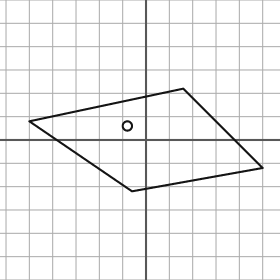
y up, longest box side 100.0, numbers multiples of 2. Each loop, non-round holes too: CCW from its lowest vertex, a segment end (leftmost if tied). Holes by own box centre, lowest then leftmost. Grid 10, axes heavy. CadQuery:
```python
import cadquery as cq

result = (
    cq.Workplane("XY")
    .moveTo(-6.0, -22.0)
    .lineTo(50.0, -12.0)
    .lineTo(16.0, 22.0)
    .lineTo(-50.0, 8.0)
    .close()
    .moveTo(-8.0, 6.0)
    .circle(2.0)
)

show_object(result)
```